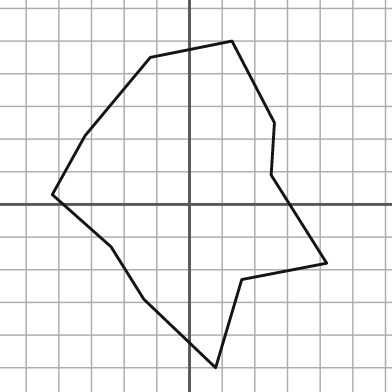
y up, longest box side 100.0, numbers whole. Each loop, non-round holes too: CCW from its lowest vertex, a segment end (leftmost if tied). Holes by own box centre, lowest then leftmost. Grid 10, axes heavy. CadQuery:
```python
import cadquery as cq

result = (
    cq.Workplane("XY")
    .moveTo(8.0, -50.0)
    .lineTo(16.0, -23.0)
    .lineTo(42.0, -18.0)
    .lineTo(25.0, 9.0)
    .lineTo(26.0, 25.0)
    .lineTo(13.0, 50.0)
    .lineTo(-12.0, 45.0)
    .lineTo(-32.0, 21.0)
    .lineTo(-42.0, 3.0)
    .lineTo(-24.0, -13.0)
    .lineTo(-14.0, -29.0)
    .close()
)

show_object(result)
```